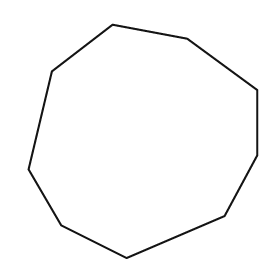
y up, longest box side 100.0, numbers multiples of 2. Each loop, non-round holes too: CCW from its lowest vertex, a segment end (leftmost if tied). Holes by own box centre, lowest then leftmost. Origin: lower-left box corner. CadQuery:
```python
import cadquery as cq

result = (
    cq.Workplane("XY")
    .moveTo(42.0, 0.0)
    .lineTo(84.0, 18.0)
    .lineTo(98.0, 44.0)
    .lineTo(98.0, 72.0)
    .lineTo(68.0, 94.0)
    .lineTo(36.0, 100.0)
    .lineTo(10.0, 80.0)
    .lineTo(0.0, 38.0)
    .lineTo(14.0, 14.0)
    .close()
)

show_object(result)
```